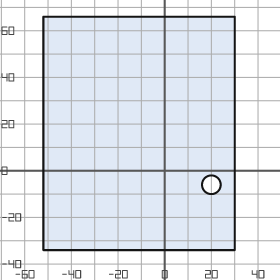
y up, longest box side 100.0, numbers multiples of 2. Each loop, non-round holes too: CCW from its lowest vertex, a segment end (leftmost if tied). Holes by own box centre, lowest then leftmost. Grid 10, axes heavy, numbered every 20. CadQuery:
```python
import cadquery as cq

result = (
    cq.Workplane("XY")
    .moveTo(-52.0, -34.0)
    .lineTo(30.0, -34.0)
    .lineTo(30.0, 66.0)
    .lineTo(-52.0, 66.0)
    .close()
    .moveTo(20.0, -6.0)
    .circle(4.0)
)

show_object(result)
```